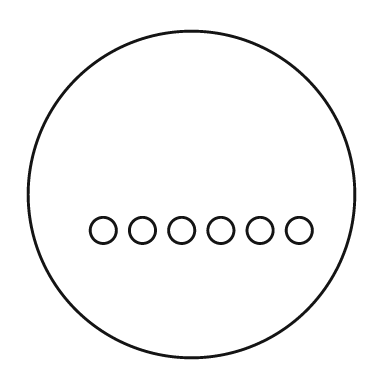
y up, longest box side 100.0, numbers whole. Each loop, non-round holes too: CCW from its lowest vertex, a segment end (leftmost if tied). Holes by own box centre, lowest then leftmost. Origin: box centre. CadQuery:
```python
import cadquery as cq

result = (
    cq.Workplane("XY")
    .moveTo(0.0, 0.0)
    .circle(50.0)
    .moveTo(-27.0, -11.0)
    .circle(4.0)
    .moveTo(-15.0, -11.0)
    .circle(4.0)
    .moveTo(-3.0, -11.0)
    .circle(4.0)
    .moveTo(9.0, -11.0)
    .circle(4.0)
    .moveTo(21.0, -11.0)
    .circle(4.0)
    .moveTo(33.0, -11.0)
    .circle(4.0)
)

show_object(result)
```